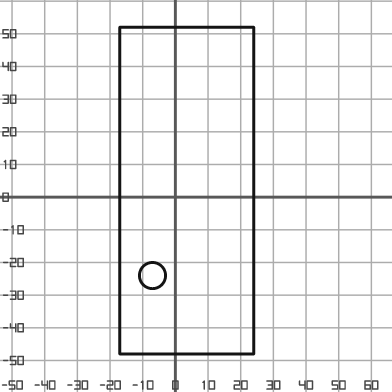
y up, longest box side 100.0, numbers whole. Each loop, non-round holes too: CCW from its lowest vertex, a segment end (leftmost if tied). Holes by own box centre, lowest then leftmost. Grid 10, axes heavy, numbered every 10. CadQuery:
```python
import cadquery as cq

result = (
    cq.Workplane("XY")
    .moveTo(-17.0, -48.0)
    .lineTo(24.0, -48.0)
    .lineTo(24.0, 52.0)
    .lineTo(-17.0, 52.0)
    .close()
    .moveTo(-7.0, -24.0)
    .circle(4.0)
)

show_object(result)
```